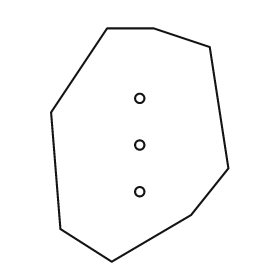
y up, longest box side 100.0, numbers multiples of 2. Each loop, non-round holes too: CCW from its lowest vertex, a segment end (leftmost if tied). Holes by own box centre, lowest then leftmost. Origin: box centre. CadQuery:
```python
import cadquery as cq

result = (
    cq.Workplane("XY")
    .moveTo(-12.0, -50.0)
    .lineTo(22.0, -30.0)
    .lineTo(38.0, -10.0)
    .lineTo(30.0, 42.0)
    .lineTo(6.0, 50.0)
    .lineTo(-14.0, 50.0)
    .lineTo(-38.0, 14.0)
    .lineTo(-34.0, -36.0)
    .close()
    .moveTo(0.0, -20.0)
    .circle(2.0)
    .moveTo(0.0, 0.0)
    .circle(2.0)
    .moveTo(0.0, 20.0)
    .circle(2.0)
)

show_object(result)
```